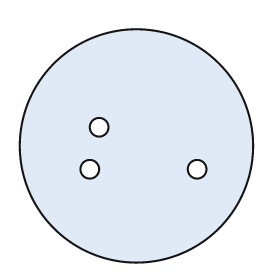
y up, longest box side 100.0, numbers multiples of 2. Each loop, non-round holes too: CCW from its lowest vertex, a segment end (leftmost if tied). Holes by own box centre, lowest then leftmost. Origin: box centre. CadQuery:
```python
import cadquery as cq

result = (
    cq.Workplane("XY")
    .moveTo(0.0, 0.0)
    .circle(50.0)
    .moveTo(-20.0, -10.0)
    .circle(4.0)
    .moveTo(26.0, -10.0)
    .circle(4.0)
    .moveTo(-16.0, 8.0)
    .circle(4.0)
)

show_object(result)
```